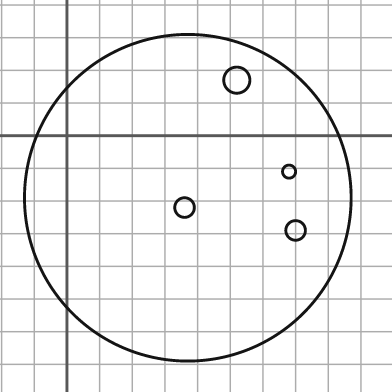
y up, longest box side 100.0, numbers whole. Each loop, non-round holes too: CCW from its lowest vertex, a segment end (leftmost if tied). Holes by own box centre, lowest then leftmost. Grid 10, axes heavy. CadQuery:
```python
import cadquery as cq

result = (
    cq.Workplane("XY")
    .moveTo(37.0, -19.0)
    .circle(50.0)
    .moveTo(70.0, -29.0)
    .circle(3.0)
    .moveTo(36.0, -22.0)
    .circle(3.0)
    .moveTo(68.0, -11.0)
    .circle(2.0)
    .moveTo(52.0, 17.0)
    .circle(4.0)
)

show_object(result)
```